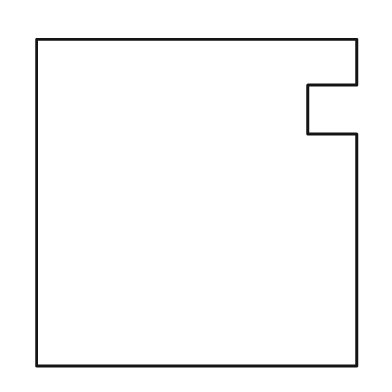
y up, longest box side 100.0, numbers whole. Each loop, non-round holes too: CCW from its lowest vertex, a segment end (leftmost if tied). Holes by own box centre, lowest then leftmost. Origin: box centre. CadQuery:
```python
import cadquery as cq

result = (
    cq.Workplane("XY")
    .moveTo(-49.0, -50.0)
    .lineTo(49.0, -50.0)
    .lineTo(49.0, 21.0)
    .lineTo(34.0, 21.0)
    .lineTo(34.0, 36.0)
    .lineTo(49.0, 36.0)
    .lineTo(49.0, 50.0)
    .lineTo(-49.0, 50.0)
    .close()
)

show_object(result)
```